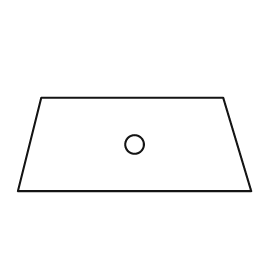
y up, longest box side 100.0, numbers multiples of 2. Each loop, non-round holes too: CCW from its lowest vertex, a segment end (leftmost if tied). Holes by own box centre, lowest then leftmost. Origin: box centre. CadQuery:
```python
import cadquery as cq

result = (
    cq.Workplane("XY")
    .moveTo(-50.0, -20.0)
    .lineTo(50.0, -20.0)
    .lineTo(38.0, 20.0)
    .lineTo(-40.0, 20.0)
    .close()
    .moveTo(0.0, 0.0)
    .circle(4.0)
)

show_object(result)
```